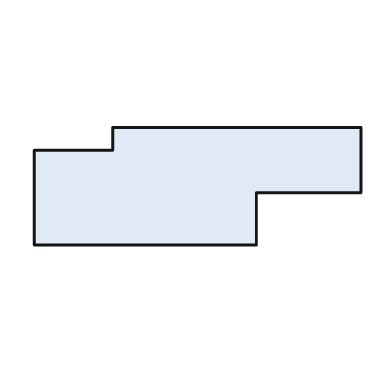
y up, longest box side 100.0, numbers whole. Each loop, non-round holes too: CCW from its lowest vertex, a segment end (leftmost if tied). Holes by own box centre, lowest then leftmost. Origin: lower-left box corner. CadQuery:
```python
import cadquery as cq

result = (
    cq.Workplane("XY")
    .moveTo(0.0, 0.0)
    .lineTo(68.0, 0.0)
    .lineTo(68.0, 16.0)
    .lineTo(100.0, 16.0)
    .lineTo(100.0, 36.0)
    .lineTo(24.0, 36.0)
    .lineTo(24.0, 29.0)
    .lineTo(0.0, 29.0)
    .close()
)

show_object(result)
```